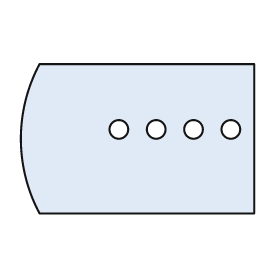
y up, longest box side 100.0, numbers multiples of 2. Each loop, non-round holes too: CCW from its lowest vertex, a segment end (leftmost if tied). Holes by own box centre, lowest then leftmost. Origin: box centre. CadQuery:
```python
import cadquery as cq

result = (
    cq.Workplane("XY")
    .moveTo(-42.0, -32.0)
    .lineTo(50.0, -32.0)
    .lineTo(50.0, 32.0)
    .lineTo(-42.0, 32.0)
    .threePointArc((-50.0, 0.0), (-42.0, -32.0))
    .close()
    .moveTo(-8.0, 4.0)
    .circle(4.0)
    .moveTo(8.0, 4.0)
    .circle(4.0)
    .moveTo(24.0, 4.0)
    .circle(4.0)
    .moveTo(40.0, 4.0)
    .circle(4.0)
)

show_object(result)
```